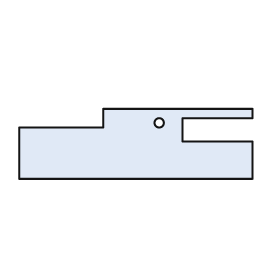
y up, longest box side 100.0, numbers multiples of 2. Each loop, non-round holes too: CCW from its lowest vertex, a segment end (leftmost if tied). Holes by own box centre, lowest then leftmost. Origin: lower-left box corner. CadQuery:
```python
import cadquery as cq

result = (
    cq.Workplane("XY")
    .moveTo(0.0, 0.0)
    .lineTo(100.0, 0.0)
    .lineTo(100.0, 16.0)
    .lineTo(70.0, 16.0)
    .lineTo(70.0, 26.0)
    .lineTo(100.0, 26.0)
    .lineTo(100.0, 30.0)
    .lineTo(36.0, 30.0)
    .lineTo(36.0, 22.0)
    .lineTo(0.0, 22.0)
    .close()
    .moveTo(60.0, 24.0)
    .circle(2.0)
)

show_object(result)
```